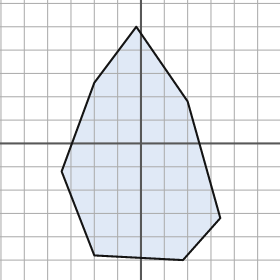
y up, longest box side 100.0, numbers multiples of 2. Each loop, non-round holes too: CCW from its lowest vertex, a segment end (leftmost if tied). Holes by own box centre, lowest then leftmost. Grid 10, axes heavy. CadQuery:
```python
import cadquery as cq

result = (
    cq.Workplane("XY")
    .moveTo(18.0, -50.0)
    .lineTo(34.0, -32.0)
    .lineTo(20.0, 18.0)
    .lineTo(-2.0, 50.0)
    .lineTo(-20.0, 26.0)
    .lineTo(-34.0, -12.0)
    .lineTo(-20.0, -48.0)
    .close()
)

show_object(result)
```